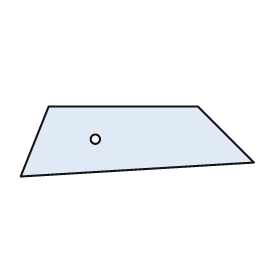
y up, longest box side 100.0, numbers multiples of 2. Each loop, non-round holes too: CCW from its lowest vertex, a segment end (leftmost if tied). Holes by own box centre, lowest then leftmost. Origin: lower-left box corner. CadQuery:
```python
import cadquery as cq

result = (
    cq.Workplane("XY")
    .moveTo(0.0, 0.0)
    .lineTo(100.0, 6.0)
    .lineTo(76.0, 30.0)
    .lineTo(12.0, 30.0)
    .close()
    .moveTo(32.0, 16.0)
    .circle(2.0)
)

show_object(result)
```